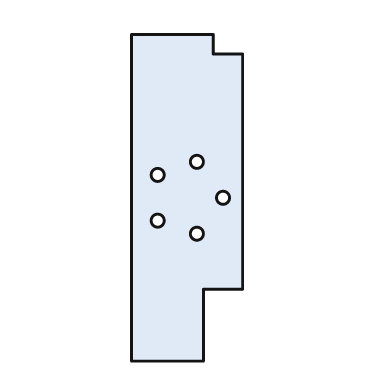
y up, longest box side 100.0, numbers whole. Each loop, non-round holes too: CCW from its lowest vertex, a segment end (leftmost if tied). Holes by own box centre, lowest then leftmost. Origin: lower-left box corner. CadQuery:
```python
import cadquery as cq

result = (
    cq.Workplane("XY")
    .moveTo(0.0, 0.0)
    .lineTo(22.0, 0.0)
    .lineTo(22.0, 22.0)
    .lineTo(34.0, 22.0)
    .lineTo(34.0, 94.0)
    .lineTo(25.0, 94.0)
    .lineTo(25.0, 100.0)
    .lineTo(0.0, 100.0)
    .close()
    .moveTo(20.0, 39.0)
    .circle(2.0)
    .moveTo(8.0, 43.0)
    .circle(2.0)
    .moveTo(28.0, 50.0)
    .circle(2.0)
    .moveTo(8.0, 57.0)
    .circle(2.0)
    .moveTo(20.0, 61.0)
    .circle(2.0)
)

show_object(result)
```